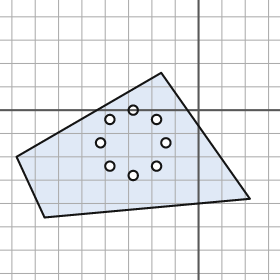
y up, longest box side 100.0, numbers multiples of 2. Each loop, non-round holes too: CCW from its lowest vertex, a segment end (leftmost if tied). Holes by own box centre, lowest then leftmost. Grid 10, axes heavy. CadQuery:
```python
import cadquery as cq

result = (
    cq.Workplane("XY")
    .moveTo(-66.0, -46.0)
    .lineTo(22.0, -38.0)
    .lineTo(-16.0, 16.0)
    .lineTo(-78.0, -20.0)
    .close()
    .moveTo(-28.0, -28.0)
    .circle(2.0)
    .moveTo(-38.0, -24.0)
    .circle(2.0)
    .moveTo(-18.0, -24.0)
    .circle(2.0)
    .moveTo(-42.0, -14.0)
    .circle(2.0)
    .moveTo(-14.0, -14.0)
    .circle(2.0)
    .moveTo(-38.0, -4.0)
    .circle(2.0)
    .moveTo(-18.0, -4.0)
    .circle(2.0)
    .moveTo(-28.0, 0.0)
    .circle(2.0)
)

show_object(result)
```